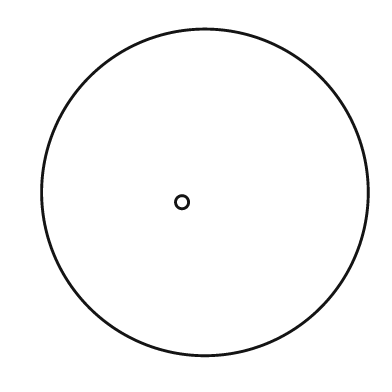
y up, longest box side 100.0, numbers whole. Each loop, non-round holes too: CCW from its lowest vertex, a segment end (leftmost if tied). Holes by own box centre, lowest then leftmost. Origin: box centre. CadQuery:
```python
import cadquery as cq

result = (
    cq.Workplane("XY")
    .moveTo(0.0, 0.0)
    .circle(50.0)
    .moveTo(-7.0, -3.0)
    .circle(2.0)
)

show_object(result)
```